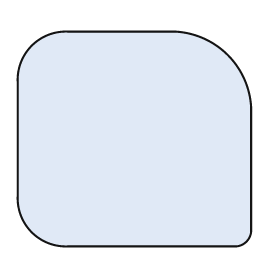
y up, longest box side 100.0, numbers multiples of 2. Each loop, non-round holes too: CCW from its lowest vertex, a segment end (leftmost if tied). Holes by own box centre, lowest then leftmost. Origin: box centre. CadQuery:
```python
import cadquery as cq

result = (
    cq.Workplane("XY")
    .moveTo(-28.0, -46.0)
    .lineTo(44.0, -46.0)
    .threePointArc((48.0, -44.0), (50.0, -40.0))
    .lineTo(50.0, 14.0)
    .threePointArc((40.0, 36.0), (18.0, 46.0))
    .lineTo(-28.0, 46.0)
    .threePointArc((-44.0, 40.0), (-50.0, 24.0))
    .lineTo(-50.0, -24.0)
    .threePointArc((-44.0, -40.0), (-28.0, -46.0))
    .close()
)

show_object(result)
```